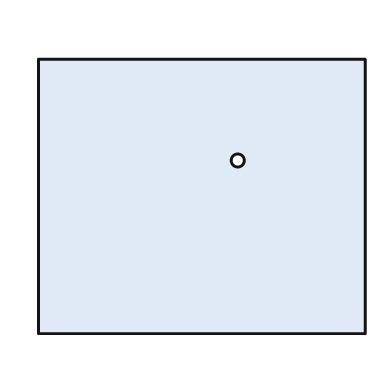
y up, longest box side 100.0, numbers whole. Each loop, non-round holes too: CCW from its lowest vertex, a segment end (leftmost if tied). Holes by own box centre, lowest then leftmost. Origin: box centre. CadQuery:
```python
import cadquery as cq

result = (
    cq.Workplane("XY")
    .moveTo(-50.0, -42.0)
    .lineTo(50.0, -42.0)
    .lineTo(50.0, 42.0)
    .lineTo(-50.0, 42.0)
    .close()
    .moveTo(11.0, 11.0)
    .circle(2.0)
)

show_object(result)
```